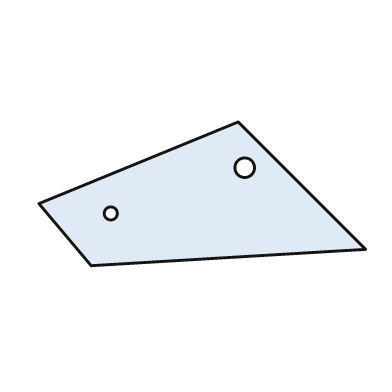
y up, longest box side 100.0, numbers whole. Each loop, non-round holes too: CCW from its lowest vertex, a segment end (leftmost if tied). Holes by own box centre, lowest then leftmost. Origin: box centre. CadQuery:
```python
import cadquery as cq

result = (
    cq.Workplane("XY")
    .moveTo(-34.0, -22.0)
    .lineTo(50.0, -17.0)
    .lineTo(11.0, 22.0)
    .lineTo(-50.0, -3.0)
    .close()
    .moveTo(-28.0, -6.0)
    .circle(2.0)
    .moveTo(13.0, 8.0)
    .circle(3.0)
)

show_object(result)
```